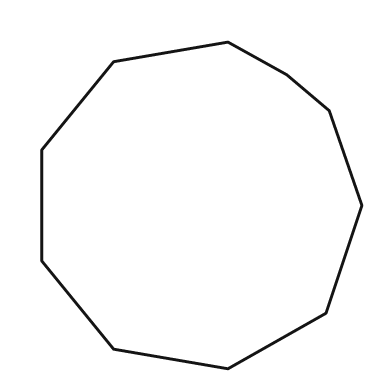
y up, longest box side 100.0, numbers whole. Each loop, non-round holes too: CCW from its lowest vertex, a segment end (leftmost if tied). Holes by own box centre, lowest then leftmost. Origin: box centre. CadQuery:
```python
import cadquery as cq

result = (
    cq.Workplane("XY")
    .moveTo(8.0, -50.0)
    .lineTo(38.0, -33.0)
    .lineTo(49.0, 0.0)
    .lineTo(39.0, 29.0)
    .lineTo(26.0, 40.0)
    .lineTo(8.0, 50.0)
    .lineTo(-27.0, 44.0)
    .lineTo(-49.0, 17.0)
    .lineTo(-49.0, -17.0)
    .lineTo(-27.0, -44.0)
    .close()
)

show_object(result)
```